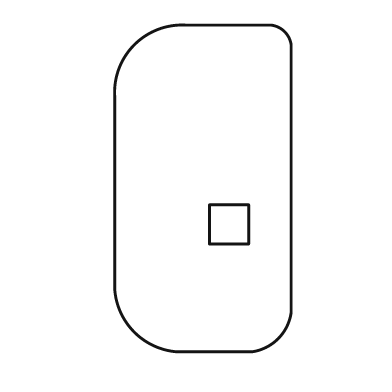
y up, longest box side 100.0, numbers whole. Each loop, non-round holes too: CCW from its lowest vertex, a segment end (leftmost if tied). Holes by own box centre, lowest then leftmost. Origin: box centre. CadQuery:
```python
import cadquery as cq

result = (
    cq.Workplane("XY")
    .moveTo(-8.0, -50.0)
    .lineTo(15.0, -50.0)
    .threePointArc((23.0, -46.0), (27.0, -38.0))
    .lineTo(27.0, 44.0)
    .threePointArc((25.0, 48.0), (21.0, 50.0))
    .lineTo(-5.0, 50.0)
    .threePointArc((-21.0, 44.0), (-27.0, 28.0))
    .lineTo(-27.0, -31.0)
    .threePointArc((-21.0, -44.0), (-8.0, -50.0))
    .close()
    .moveTo(2.0, -17.0)
    .lineTo(14.0, -17.0)
    .lineTo(14.0, -5.0)
    .lineTo(2.0, -5.0)
    .close()
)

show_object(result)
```